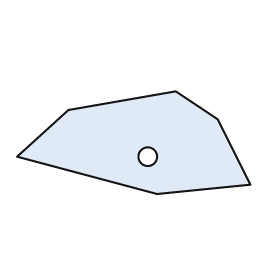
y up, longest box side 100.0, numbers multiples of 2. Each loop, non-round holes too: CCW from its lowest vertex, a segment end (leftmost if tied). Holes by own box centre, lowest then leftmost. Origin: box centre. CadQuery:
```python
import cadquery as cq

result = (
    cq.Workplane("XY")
    .moveTo(10.0, -22.0)
    .lineTo(50.0, -18.0)
    .lineTo(36.0, 10.0)
    .lineTo(18.0, 22.0)
    .lineTo(-28.0, 14.0)
    .lineTo(-50.0, -6.0)
    .close()
    .moveTo(6.0, -6.0)
    .circle(4.0)
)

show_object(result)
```